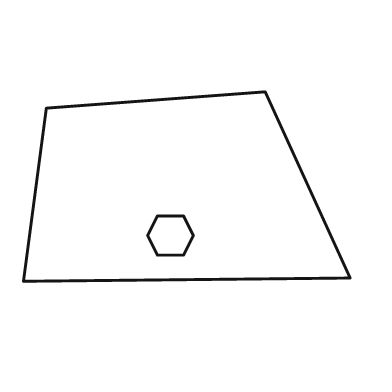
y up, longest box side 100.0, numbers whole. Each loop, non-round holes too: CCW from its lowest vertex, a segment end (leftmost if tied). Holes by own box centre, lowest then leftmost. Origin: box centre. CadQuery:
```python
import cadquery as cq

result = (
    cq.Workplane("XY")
    .moveTo(-50.0, -29.0)
    .lineTo(50.0, -28.0)
    .lineTo(24.0, 29.0)
    .lineTo(-43.0, 24.0)
    .close()
    .moveTo(-9.0, -21.0)
    .lineTo(-1.0, -21.0)
    .lineTo(2.0, -15.0)
    .lineTo(-1.0, -9.0)
    .lineTo(-9.0, -9.0)
    .lineTo(-12.0, -15.0)
    .close()
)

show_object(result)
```